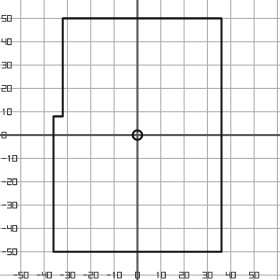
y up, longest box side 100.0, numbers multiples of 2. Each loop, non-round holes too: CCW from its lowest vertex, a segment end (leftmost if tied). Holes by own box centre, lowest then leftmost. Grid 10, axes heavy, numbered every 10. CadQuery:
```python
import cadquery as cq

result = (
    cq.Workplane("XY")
    .moveTo(-36.0, -50.0)
    .lineTo(36.0, -50.0)
    .lineTo(36.0, 50.0)
    .lineTo(-32.0, 50.0)
    .lineTo(-32.0, 8.0)
    .lineTo(-36.0, 8.0)
    .close()
    .moveTo(0.0, 0.0)
    .circle(2.0)
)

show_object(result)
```